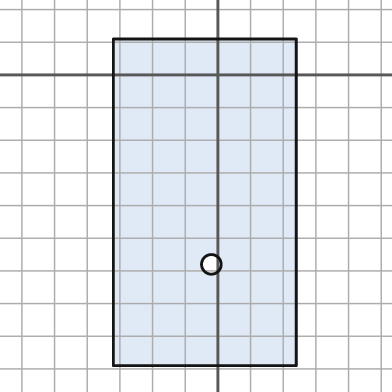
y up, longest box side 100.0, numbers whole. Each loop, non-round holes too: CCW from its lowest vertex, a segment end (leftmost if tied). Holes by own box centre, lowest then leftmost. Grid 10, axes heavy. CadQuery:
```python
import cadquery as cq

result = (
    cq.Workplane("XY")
    .moveTo(-32.0, -89.0)
    .lineTo(24.0, -89.0)
    .lineTo(24.0, 11.0)
    .lineTo(-32.0, 11.0)
    .close()
    .moveTo(-2.0, -58.0)
    .circle(3.0)
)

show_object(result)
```